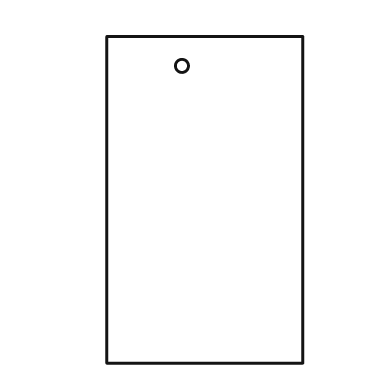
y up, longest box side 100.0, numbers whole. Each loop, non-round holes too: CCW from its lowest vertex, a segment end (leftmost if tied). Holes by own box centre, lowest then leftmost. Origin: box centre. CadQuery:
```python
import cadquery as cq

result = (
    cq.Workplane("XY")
    .moveTo(-30.0, -50.0)
    .lineTo(30.0, -50.0)
    .lineTo(30.0, 50.0)
    .lineTo(-30.0, 50.0)
    .close()
    .moveTo(-7.0, 41.0)
    .circle(2.0)
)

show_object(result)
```